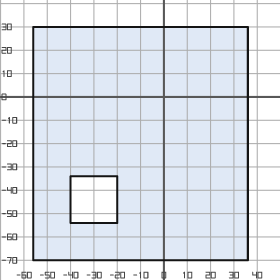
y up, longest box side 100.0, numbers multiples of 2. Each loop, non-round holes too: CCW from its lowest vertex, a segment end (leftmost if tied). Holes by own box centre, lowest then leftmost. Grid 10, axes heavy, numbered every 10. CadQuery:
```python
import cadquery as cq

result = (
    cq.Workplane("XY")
    .moveTo(-56.0, -70.0)
    .lineTo(36.0, -70.0)
    .lineTo(36.0, 30.0)
    .lineTo(-56.0, 30.0)
    .close()
    .moveTo(-40.0, -54.0)
    .lineTo(-20.0, -54.0)
    .lineTo(-20.0, -34.0)
    .lineTo(-40.0, -34.0)
    .close()
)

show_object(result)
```